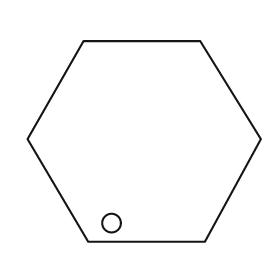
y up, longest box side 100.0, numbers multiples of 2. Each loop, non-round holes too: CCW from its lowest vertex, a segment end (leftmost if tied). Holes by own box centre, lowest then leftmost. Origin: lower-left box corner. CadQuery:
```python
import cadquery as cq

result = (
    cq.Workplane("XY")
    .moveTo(26.0, 0.0)
    .lineTo(76.0, 0.0)
    .lineTo(100.0, 44.0)
    .lineTo(74.0, 86.0)
    .lineTo(24.0, 86.0)
    .lineTo(0.0, 44.0)
    .close()
    .moveTo(36.0, 8.0)
    .circle(4.0)
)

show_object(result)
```